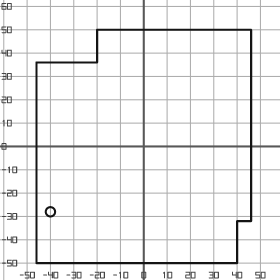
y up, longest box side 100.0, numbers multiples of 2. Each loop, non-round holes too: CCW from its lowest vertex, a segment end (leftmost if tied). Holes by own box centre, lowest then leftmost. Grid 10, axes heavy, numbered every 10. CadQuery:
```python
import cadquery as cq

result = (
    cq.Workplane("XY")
    .moveTo(-46.0, -50.0)
    .lineTo(40.0, -50.0)
    .lineTo(40.0, -32.0)
    .lineTo(46.0, -32.0)
    .lineTo(46.0, 50.0)
    .lineTo(-20.0, 50.0)
    .lineTo(-20.0, 36.0)
    .lineTo(-46.0, 36.0)
    .close()
    .moveTo(-40.0, -28.0)
    .circle(2.0)
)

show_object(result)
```